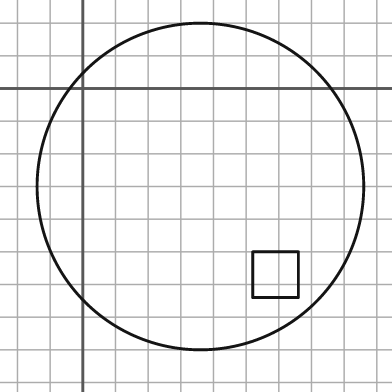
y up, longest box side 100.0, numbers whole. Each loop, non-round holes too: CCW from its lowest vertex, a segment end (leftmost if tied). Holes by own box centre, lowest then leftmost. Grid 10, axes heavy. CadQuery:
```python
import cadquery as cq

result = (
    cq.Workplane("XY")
    .moveTo(36.0, -30.0)
    .circle(50.0)
    .moveTo(52.0, -64.0)
    .lineTo(66.0, -64.0)
    .lineTo(66.0, -50.0)
    .lineTo(52.0, -50.0)
    .close()
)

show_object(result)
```